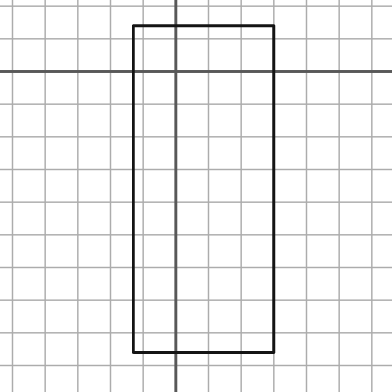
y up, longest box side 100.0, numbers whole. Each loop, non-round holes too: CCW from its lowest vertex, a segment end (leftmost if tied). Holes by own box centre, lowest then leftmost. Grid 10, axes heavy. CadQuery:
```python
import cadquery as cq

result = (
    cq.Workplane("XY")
    .moveTo(-13.0, -86.0)
    .lineTo(30.0, -86.0)
    .lineTo(30.0, 14.0)
    .lineTo(-13.0, 14.0)
    .close()
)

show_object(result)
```